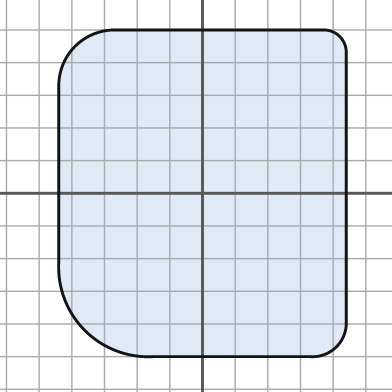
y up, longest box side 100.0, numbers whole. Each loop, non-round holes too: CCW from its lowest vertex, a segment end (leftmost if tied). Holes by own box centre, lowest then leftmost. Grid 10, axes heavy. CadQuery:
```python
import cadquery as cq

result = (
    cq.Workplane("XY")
    .moveTo(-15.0, -50.0)
    .lineTo(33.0, -50.0)
    .threePointArc((41.0, -47.0), (44.0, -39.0))
    .lineTo(44.0, 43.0)
    .threePointArc((42.0, 48.0), (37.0, 50.0))
    .lineTo(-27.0, 50.0)
    .threePointArc((-39.0, 45.0), (-44.0, 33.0))
    .lineTo(-44.0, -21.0)
    .threePointArc((-36.0, -42.0), (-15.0, -50.0))
    .close()
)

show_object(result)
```